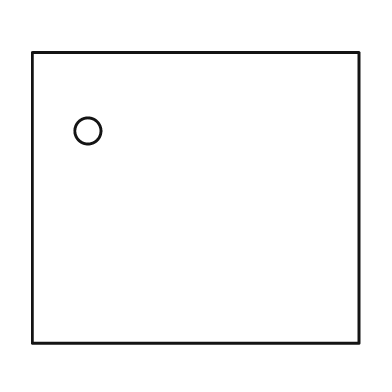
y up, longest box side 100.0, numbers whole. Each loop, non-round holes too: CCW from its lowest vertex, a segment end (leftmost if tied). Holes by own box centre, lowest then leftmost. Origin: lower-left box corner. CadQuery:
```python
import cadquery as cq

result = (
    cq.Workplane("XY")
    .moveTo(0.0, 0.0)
    .lineTo(100.0, 0.0)
    .lineTo(100.0, 89.0)
    .lineTo(0.0, 89.0)
    .close()
    .moveTo(17.0, 65.0)
    .circle(4.0)
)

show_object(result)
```